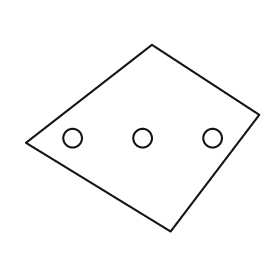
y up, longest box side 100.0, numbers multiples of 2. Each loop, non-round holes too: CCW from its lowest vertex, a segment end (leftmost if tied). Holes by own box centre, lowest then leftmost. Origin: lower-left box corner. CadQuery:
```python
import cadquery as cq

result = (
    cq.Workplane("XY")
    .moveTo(62.0, 0.0)
    .lineTo(100.0, 50.0)
    .lineTo(54.0, 80.0)
    .lineTo(0.0, 38.0)
    .close()
    .moveTo(20.0, 40.0)
    .circle(4.0)
    .moveTo(50.0, 40.0)
    .circle(4.0)
    .moveTo(80.0, 40.0)
    .circle(4.0)
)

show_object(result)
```